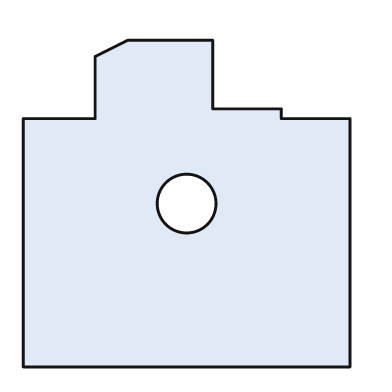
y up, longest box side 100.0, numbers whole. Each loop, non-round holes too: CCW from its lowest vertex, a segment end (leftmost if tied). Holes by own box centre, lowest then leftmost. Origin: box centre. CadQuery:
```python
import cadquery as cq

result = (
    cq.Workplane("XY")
    .moveTo(-50.0, -50.0)
    .lineTo(50.0, -50.0)
    .lineTo(50.0, 26.0)
    .lineTo(29.0, 26.0)
    .lineTo(29.0, 29.0)
    .lineTo(8.0, 29.0)
    .lineTo(8.0, 50.0)
    .lineTo(-18.0, 50.0)
    .lineTo(-28.0, 45.0)
    .lineTo(-28.0, 26.0)
    .lineTo(-50.0, 26.0)
    .close()
    .moveTo(0.0, 0.0)
    .circle(9.0)
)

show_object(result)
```